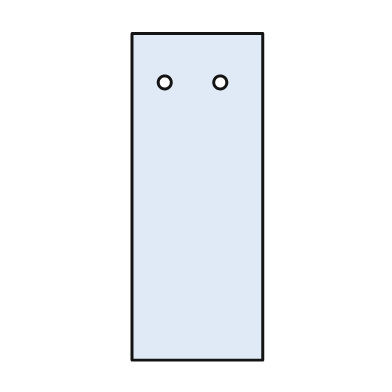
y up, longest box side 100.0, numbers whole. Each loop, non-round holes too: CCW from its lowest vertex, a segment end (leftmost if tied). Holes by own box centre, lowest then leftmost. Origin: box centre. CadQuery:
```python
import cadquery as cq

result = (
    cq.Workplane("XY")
    .moveTo(-20.0, -50.0)
    .lineTo(20.0, -50.0)
    .lineTo(20.0, 50.0)
    .lineTo(-20.0, 50.0)
    .close()
    .moveTo(-10.0, 35.0)
    .circle(2.0)
    .moveTo(7.0, 35.0)
    .circle(2.0)
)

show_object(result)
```